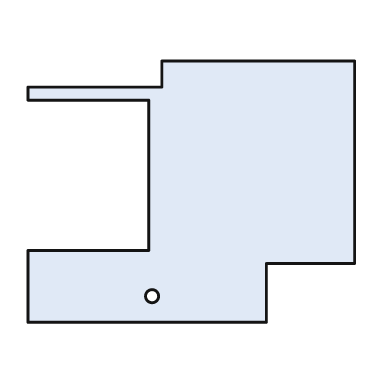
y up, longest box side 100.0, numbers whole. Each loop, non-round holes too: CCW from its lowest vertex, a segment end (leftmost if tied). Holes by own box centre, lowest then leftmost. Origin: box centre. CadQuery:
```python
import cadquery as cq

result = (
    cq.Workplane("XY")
    .moveTo(-50.0, -40.0)
    .lineTo(23.0, -40.0)
    .lineTo(23.0, -22.0)
    .lineTo(50.0, -22.0)
    .lineTo(50.0, 40.0)
    .lineTo(-9.0, 40.0)
    .lineTo(-9.0, 32.0)
    .lineTo(-50.0, 32.0)
    .lineTo(-50.0, 28.0)
    .lineTo(-13.0, 28.0)
    .lineTo(-13.0, -18.0)
    .lineTo(-50.0, -18.0)
    .close()
    .moveTo(-12.0, -32.0)
    .circle(2.0)
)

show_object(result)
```